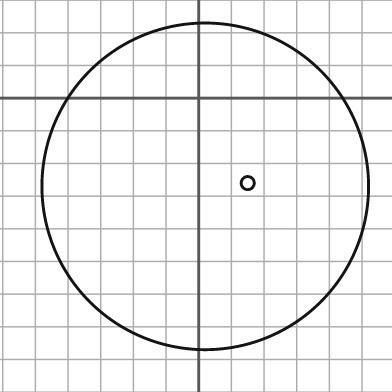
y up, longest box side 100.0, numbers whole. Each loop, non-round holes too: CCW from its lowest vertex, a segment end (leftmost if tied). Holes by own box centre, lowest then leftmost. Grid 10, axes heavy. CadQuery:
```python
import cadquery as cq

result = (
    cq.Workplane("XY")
    .moveTo(2.0, -27.0)
    .circle(50.0)
    .moveTo(15.0, -26.0)
    .circle(2.0)
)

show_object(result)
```